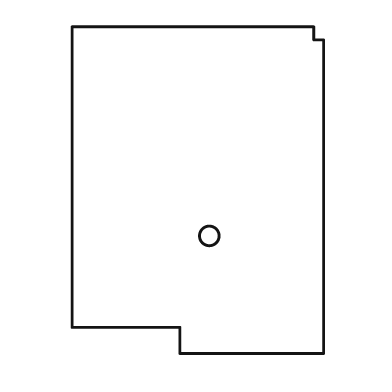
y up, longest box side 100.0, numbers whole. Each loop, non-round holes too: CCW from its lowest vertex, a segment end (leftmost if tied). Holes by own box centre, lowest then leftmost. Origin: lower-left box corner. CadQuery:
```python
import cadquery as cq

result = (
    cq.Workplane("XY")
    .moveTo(33.0, 0.0)
    .lineTo(77.0, 0.0)
    .lineTo(77.0, 96.0)
    .lineTo(74.0, 96.0)
    .lineTo(74.0, 100.0)
    .lineTo(0.0, 100.0)
    .lineTo(0.0, 8.0)
    .lineTo(33.0, 8.0)
    .close()
    .moveTo(42.0, 36.0)
    .circle(3.0)
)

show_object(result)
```